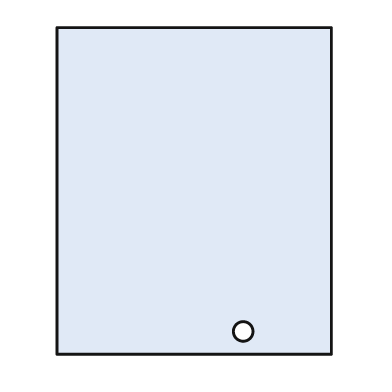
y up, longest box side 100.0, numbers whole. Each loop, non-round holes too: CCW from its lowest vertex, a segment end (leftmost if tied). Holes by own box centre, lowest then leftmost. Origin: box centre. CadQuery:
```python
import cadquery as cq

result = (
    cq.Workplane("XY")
    .moveTo(-42.0, -50.0)
    .lineTo(42.0, -50.0)
    .lineTo(42.0, 50.0)
    .lineTo(-42.0, 50.0)
    .close()
    .moveTo(15.0, -43.0)
    .circle(3.0)
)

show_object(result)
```